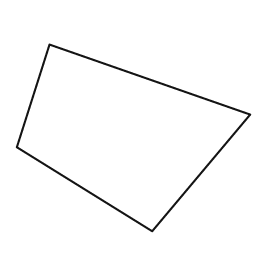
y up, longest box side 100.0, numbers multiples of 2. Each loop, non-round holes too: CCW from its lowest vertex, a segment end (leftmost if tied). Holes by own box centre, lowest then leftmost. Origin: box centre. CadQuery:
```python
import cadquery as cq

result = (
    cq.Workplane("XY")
    .moveTo(8.0, -40.0)
    .lineTo(50.0, 10.0)
    .lineTo(-36.0, 40.0)
    .lineTo(-50.0, -4.0)
    .close()
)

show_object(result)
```